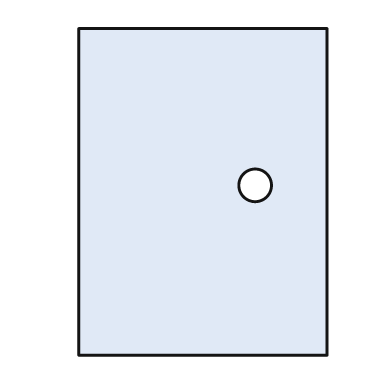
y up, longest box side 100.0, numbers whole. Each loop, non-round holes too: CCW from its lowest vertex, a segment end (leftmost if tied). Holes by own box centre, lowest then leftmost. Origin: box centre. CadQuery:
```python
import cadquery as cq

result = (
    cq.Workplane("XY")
    .moveTo(-38.0, -50.0)
    .lineTo(38.0, -50.0)
    .lineTo(38.0, 50.0)
    .lineTo(-38.0, 50.0)
    .close()
    .moveTo(16.0, 2.0)
    .circle(5.0)
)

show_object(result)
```